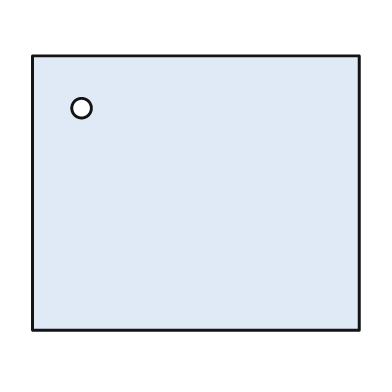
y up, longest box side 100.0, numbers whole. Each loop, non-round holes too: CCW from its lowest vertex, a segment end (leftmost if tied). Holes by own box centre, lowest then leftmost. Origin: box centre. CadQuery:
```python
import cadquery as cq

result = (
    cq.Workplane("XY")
    .moveTo(-50.0, -42.0)
    .lineTo(50.0, -42.0)
    .lineTo(50.0, 42.0)
    .lineTo(-50.0, 42.0)
    .close()
    .moveTo(-35.0, 26.0)
    .circle(3.0)
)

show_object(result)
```